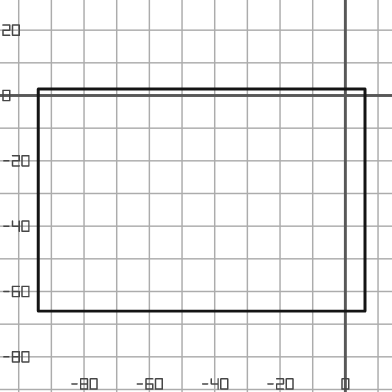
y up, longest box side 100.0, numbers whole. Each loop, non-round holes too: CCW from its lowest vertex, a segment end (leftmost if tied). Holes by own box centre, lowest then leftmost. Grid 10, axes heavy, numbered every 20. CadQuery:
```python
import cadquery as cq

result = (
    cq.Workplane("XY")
    .moveTo(-94.0, -66.0)
    .lineTo(6.0, -66.0)
    .lineTo(6.0, 2.0)
    .lineTo(-94.0, 2.0)
    .close()
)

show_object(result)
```